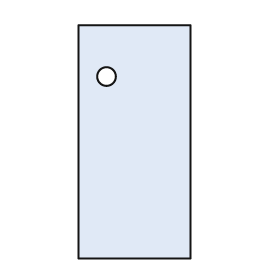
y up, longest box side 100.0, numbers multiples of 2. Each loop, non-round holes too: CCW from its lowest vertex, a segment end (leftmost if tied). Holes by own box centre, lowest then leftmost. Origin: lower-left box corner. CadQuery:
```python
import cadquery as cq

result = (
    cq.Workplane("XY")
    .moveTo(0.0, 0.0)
    .lineTo(48.0, 0.0)
    .lineTo(48.0, 100.0)
    .lineTo(0.0, 100.0)
    .close()
    .moveTo(12.0, 78.0)
    .circle(4.0)
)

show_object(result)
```